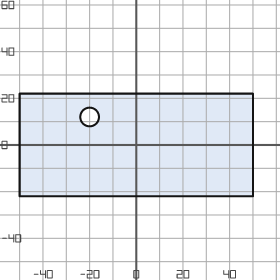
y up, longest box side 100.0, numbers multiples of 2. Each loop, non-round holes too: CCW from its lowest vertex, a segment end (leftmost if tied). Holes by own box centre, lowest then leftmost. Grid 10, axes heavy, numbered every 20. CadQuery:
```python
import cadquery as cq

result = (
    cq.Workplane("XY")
    .moveTo(-50.0, -22.0)
    .lineTo(50.0, -22.0)
    .lineTo(50.0, 22.0)
    .lineTo(-50.0, 22.0)
    .close()
    .moveTo(-20.0, 12.0)
    .circle(4.0)
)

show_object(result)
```